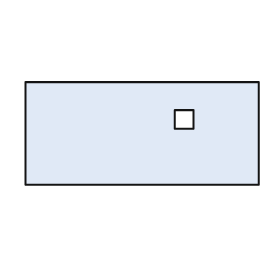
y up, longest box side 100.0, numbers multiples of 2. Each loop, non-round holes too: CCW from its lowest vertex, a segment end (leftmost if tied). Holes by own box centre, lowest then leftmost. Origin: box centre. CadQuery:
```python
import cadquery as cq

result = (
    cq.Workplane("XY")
    .moveTo(-50.0, -22.0)
    .lineTo(50.0, -22.0)
    .lineTo(50.0, 22.0)
    .lineTo(-50.0, 22.0)
    .close()
    .moveTo(14.0, 2.0)
    .lineTo(22.0, 2.0)
    .lineTo(22.0, 10.0)
    .lineTo(14.0, 10.0)
    .close()
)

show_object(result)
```